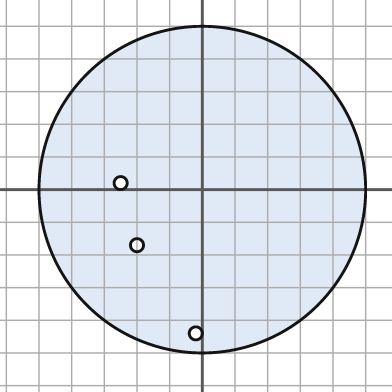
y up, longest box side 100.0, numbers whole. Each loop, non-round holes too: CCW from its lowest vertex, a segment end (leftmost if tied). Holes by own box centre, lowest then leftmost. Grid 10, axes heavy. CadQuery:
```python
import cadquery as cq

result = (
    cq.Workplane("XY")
    .moveTo(0.0, 0.0)
    .circle(50.0)
    .moveTo(-2.0, -44.0)
    .circle(2.0)
    .moveTo(-20.0, -17.0)
    .circle(2.0)
    .moveTo(-25.0, 2.0)
    .circle(2.0)
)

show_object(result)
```